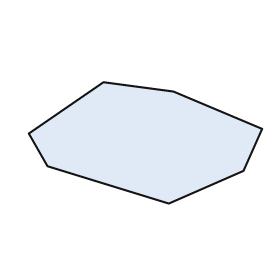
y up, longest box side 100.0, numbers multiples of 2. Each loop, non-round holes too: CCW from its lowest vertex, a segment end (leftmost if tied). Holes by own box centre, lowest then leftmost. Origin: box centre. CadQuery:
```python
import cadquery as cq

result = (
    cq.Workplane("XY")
    .moveTo(10.0, -26.0)
    .lineTo(42.0, -12.0)
    .lineTo(50.0, 6.0)
    .lineTo(12.0, 22.0)
    .lineTo(-18.0, 26.0)
    .lineTo(-50.0, 4.0)
    .lineTo(-42.0, -10.0)
    .close()
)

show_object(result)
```